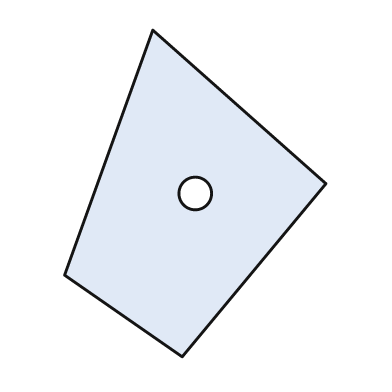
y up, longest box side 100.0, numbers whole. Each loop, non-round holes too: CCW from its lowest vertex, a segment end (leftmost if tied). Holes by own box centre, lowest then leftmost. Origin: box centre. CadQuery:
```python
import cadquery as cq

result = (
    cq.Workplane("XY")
    .moveTo(-4.0, -50.0)
    .lineTo(40.0, 3.0)
    .lineTo(-13.0, 50.0)
    .lineTo(-40.0, -25.0)
    .close()
    .moveTo(0.0, 0.0)
    .circle(5.0)
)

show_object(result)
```